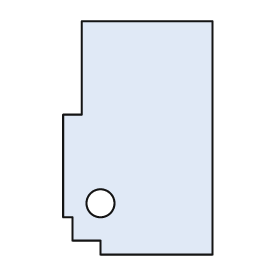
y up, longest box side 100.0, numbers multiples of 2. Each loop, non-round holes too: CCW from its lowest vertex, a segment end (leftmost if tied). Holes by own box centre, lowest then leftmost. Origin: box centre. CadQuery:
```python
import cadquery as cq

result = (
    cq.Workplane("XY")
    .moveTo(-16.0, -50.0)
    .lineTo(32.0, -50.0)
    .lineTo(32.0, 50.0)
    .lineTo(-24.0, 50.0)
    .lineTo(-24.0, 10.0)
    .lineTo(-32.0, 10.0)
    .lineTo(-32.0, -34.0)
    .lineTo(-28.0, -34.0)
    .lineTo(-28.0, -44.0)
    .lineTo(-16.0, -44.0)
    .close()
    .moveTo(-16.0, -28.0)
    .circle(6.0)
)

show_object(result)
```